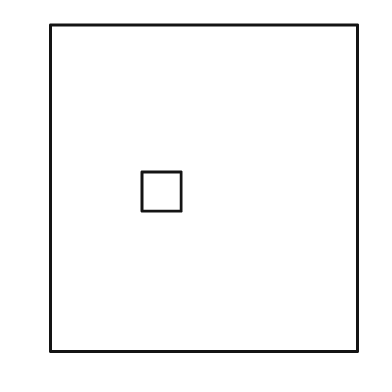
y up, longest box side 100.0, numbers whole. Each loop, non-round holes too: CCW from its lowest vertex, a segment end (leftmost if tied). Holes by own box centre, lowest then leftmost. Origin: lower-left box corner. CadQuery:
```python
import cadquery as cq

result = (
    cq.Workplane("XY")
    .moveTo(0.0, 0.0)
    .lineTo(94.0, 0.0)
    .lineTo(94.0, 100.0)
    .lineTo(0.0, 100.0)
    .close()
    .moveTo(28.0, 43.0)
    .lineTo(40.0, 43.0)
    .lineTo(40.0, 55.0)
    .lineTo(28.0, 55.0)
    .close()
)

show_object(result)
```